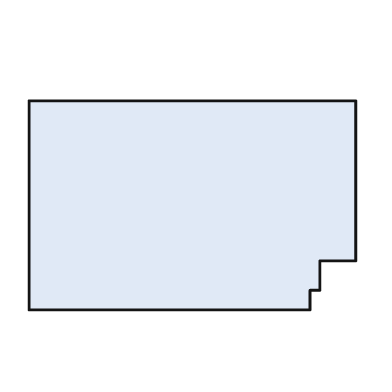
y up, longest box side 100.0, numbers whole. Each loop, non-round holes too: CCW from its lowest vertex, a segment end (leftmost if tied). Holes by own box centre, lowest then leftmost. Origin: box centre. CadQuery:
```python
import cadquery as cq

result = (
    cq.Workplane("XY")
    .moveTo(-50.0, -32.0)
    .lineTo(36.0, -32.0)
    .lineTo(36.0, -26.0)
    .lineTo(39.0, -26.0)
    .lineTo(39.0, -17.0)
    .lineTo(50.0, -17.0)
    .lineTo(50.0, 32.0)
    .lineTo(-50.0, 32.0)
    .close()
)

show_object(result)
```